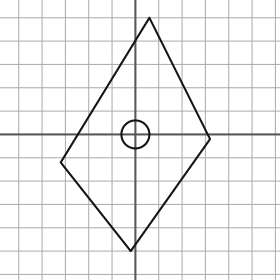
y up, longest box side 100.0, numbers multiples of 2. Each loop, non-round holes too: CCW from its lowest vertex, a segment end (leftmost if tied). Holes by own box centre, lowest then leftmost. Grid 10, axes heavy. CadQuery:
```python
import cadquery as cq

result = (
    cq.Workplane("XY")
    .moveTo(-2.0, -50.0)
    .lineTo(32.0, -2.0)
    .lineTo(6.0, 50.0)
    .lineTo(-32.0, -12.0)
    .close()
    .moveTo(0.0, 0.0)
    .circle(6.0)
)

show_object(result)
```